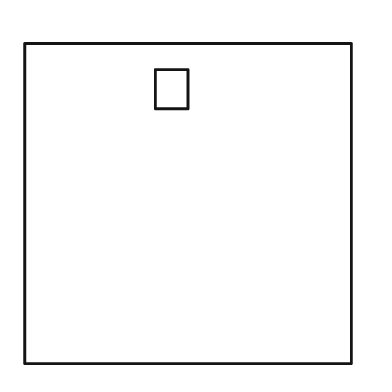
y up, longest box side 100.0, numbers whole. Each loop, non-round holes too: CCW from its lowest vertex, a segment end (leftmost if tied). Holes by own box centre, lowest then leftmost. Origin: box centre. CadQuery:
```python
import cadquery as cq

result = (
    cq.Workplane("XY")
    .moveTo(-50.0, -49.0)
    .lineTo(50.0, -49.0)
    .lineTo(50.0, 49.0)
    .lineTo(-50.0, 49.0)
    .close()
    .moveTo(-10.0, 29.0)
    .lineTo(0.0, 29.0)
    .lineTo(0.0, 41.0)
    .lineTo(-10.0, 41.0)
    .close()
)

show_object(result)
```